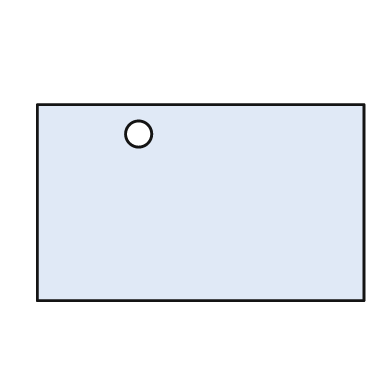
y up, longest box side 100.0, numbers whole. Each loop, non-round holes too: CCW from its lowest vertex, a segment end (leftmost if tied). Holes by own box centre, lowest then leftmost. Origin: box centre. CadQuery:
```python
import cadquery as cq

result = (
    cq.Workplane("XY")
    .moveTo(-50.0, -30.0)
    .lineTo(50.0, -30.0)
    .lineTo(50.0, 30.0)
    .lineTo(-50.0, 30.0)
    .close()
    .moveTo(-19.0, 21.0)
    .circle(4.0)
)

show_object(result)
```